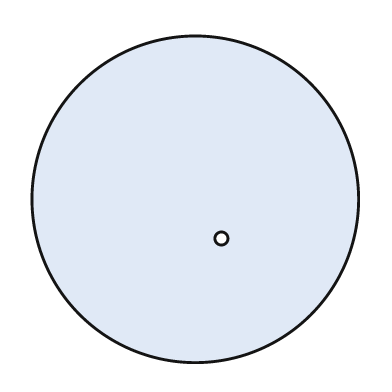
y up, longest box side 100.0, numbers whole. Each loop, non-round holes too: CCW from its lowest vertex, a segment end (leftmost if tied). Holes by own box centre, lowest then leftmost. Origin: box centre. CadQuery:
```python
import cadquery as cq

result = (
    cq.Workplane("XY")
    .moveTo(0.0, 0.0)
    .circle(50.0)
    .moveTo(8.0, -12.0)
    .circle(2.0)
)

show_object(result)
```